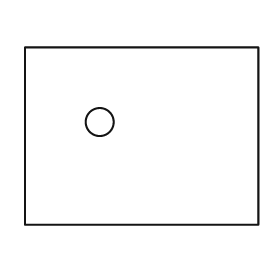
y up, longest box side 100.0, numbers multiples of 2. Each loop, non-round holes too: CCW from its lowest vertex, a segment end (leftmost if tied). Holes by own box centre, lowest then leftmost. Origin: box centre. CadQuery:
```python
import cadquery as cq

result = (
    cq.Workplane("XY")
    .moveTo(-50.0, -38.0)
    .lineTo(50.0, -38.0)
    .lineTo(50.0, 38.0)
    .lineTo(-50.0, 38.0)
    .close()
    .moveTo(-18.0, 6.0)
    .circle(6.0)
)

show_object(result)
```